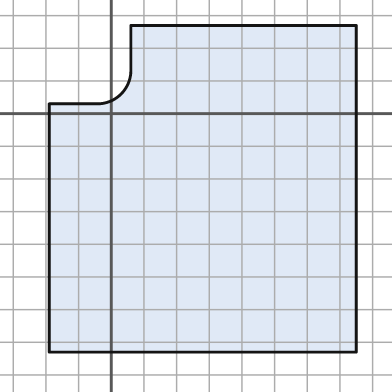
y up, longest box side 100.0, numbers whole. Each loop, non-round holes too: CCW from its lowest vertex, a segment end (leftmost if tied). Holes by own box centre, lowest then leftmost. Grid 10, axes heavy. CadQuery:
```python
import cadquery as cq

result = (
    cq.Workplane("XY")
    .moveTo(-19.0, -73.0)
    .lineTo(75.0, -73.0)
    .lineTo(75.0, 27.0)
    .lineTo(6.0, 27.0)
    .lineTo(6.0, 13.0)
    .threePointArc((3.0, 6.0), (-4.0, 3.0))
    .lineTo(-19.0, 3.0)
    .close()
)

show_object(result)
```